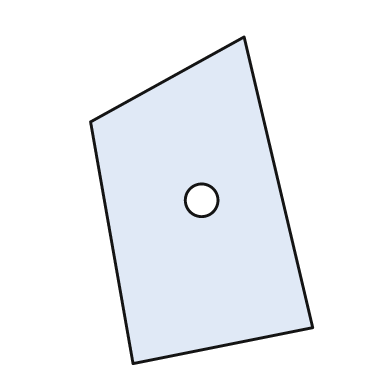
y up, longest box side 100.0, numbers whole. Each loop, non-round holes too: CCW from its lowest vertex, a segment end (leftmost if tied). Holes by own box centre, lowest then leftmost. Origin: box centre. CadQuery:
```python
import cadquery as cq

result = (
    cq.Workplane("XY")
    .moveTo(-21.0, -50.0)
    .lineTo(34.0, -39.0)
    .lineTo(13.0, 50.0)
    .lineTo(-34.0, 24.0)
    .close()
    .moveTo(0.0, 0.0)
    .circle(5.0)
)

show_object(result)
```